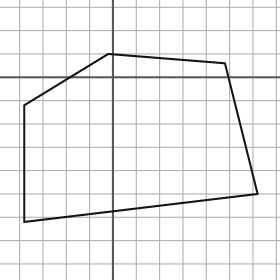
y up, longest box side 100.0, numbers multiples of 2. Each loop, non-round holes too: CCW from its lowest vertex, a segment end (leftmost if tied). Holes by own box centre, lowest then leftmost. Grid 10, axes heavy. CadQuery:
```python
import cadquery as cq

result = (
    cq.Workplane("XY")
    .moveTo(-38.0, -62.0)
    .lineTo(62.0, -50.0)
    .lineTo(48.0, 6.0)
    .lineTo(-2.0, 10.0)
    .lineTo(-38.0, -12.0)
    .close()
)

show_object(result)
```